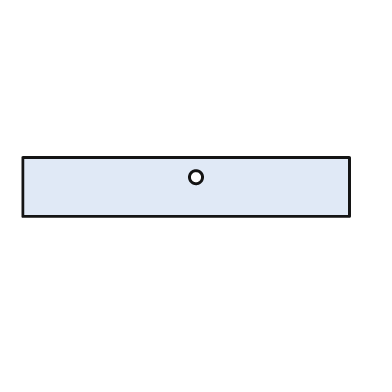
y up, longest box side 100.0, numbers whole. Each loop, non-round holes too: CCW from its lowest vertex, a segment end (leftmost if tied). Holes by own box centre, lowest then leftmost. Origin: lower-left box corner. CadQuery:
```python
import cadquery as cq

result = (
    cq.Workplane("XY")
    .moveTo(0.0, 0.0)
    .lineTo(100.0, 0.0)
    .lineTo(100.0, 18.0)
    .lineTo(0.0, 18.0)
    .close()
    .moveTo(53.0, 12.0)
    .circle(2.0)
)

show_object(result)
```